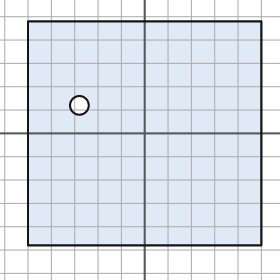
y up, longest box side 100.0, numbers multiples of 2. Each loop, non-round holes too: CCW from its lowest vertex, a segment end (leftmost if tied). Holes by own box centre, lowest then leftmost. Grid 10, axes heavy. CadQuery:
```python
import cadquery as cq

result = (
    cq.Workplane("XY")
    .moveTo(-50.0, -48.0)
    .lineTo(50.0, -48.0)
    .lineTo(50.0, 48.0)
    .lineTo(-50.0, 48.0)
    .close()
    .moveTo(-28.0, 12.0)
    .circle(4.0)
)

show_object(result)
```